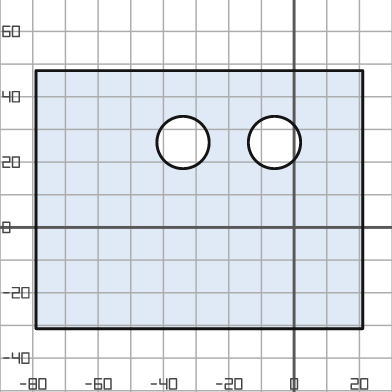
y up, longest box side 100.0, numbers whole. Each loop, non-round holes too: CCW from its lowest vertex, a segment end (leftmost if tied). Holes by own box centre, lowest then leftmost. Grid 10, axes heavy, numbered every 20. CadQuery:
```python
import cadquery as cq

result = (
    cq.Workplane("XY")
    .moveTo(-79.0, -31.0)
    .lineTo(21.0, -31.0)
    .lineTo(21.0, 48.0)
    .lineTo(-79.0, 48.0)
    .close()
    .moveTo(-34.0, 26.0)
    .circle(8.0)
    .moveTo(-6.0, 26.0)
    .circle(8.0)
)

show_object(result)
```